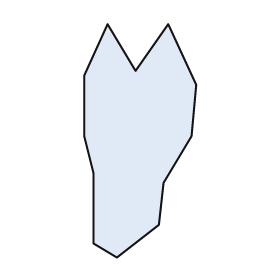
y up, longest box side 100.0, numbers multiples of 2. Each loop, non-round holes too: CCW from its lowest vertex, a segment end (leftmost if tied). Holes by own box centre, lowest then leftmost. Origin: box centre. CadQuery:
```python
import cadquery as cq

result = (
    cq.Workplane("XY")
    .moveTo(-10.0, -50.0)
    .lineTo(8.0, -36.0)
    .lineTo(10.0, -18.0)
    .lineTo(22.0, 2.0)
    .lineTo(24.0, 24.0)
    .lineTo(12.0, 50.0)
    .lineTo(-2.0, 30.0)
    .lineTo(-14.0, 50.0)
    .lineTo(-24.0, 28.0)
    .lineTo(-24.0, 2.0)
    .lineTo(-20.0, -14.0)
    .lineTo(-20.0, -44.0)
    .close()
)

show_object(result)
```